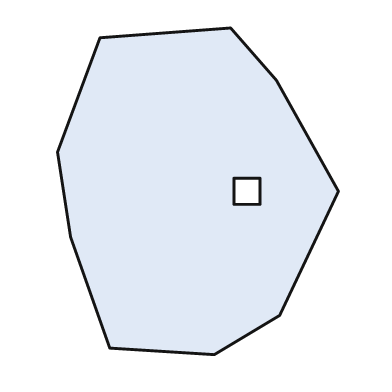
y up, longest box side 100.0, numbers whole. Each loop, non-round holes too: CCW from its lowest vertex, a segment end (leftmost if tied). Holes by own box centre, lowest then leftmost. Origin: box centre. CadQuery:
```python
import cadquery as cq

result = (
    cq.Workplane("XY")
    .moveTo(5.0, -50.0)
    .lineTo(25.0, -38.0)
    .lineTo(43.0, 0.0)
    .lineTo(24.0, 34.0)
    .lineTo(10.0, 50.0)
    .lineTo(-30.0, 47.0)
    .lineTo(-43.0, 12.0)
    .lineTo(-39.0, -14.0)
    .lineTo(-27.0, -48.0)
    .close()
    .moveTo(11.0, -4.0)
    .lineTo(19.0, -4.0)
    .lineTo(19.0, 4.0)
    .lineTo(11.0, 4.0)
    .close()
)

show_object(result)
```